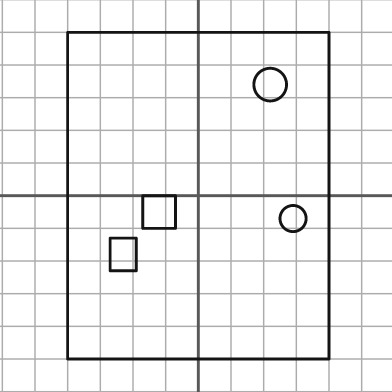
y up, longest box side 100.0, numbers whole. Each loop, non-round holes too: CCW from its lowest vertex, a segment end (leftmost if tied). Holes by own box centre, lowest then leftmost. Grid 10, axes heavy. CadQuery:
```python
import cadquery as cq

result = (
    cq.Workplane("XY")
    .moveTo(-40.0, -50.0)
    .lineTo(40.0, -50.0)
    .lineTo(40.0, 50.0)
    .lineTo(-40.0, 50.0)
    .close()
    .moveTo(-27.0, -23.0)
    .lineTo(-19.0, -23.0)
    .lineTo(-19.0, -13.0)
    .lineTo(-27.0, -13.0)
    .close()
    .moveTo(29.0, -7.0)
    .circle(4.0)
    .moveTo(-17.0, -10.0)
    .lineTo(-7.0, -10.0)
    .lineTo(-7.0, 0.0)
    .lineTo(-17.0, 0.0)
    .close()
    .moveTo(22.0, 34.0)
    .circle(5.0)
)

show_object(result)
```